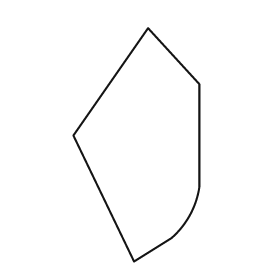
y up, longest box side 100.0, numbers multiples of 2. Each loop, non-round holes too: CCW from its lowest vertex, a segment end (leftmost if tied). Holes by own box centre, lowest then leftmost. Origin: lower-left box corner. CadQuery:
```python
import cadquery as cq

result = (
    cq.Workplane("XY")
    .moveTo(26.0, 0.0)
    .lineTo(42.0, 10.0)
    .threePointArc((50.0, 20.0), (54.0, 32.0))
    .lineTo(54.0, 76.0)
    .lineTo(32.0, 100.0)
    .lineTo(0.0, 54.0)
    .close()
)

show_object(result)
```